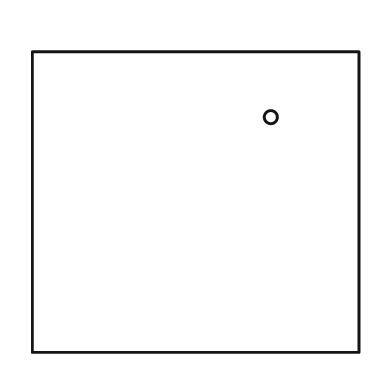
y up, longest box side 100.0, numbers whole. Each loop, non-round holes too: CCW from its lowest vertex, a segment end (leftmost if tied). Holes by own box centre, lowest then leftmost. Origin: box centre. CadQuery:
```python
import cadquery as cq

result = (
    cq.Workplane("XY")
    .moveTo(-50.0, -46.0)
    .lineTo(50.0, -46.0)
    .lineTo(50.0, 46.0)
    .lineTo(-50.0, 46.0)
    .close()
    .moveTo(23.0, 26.0)
    .circle(2.0)
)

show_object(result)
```